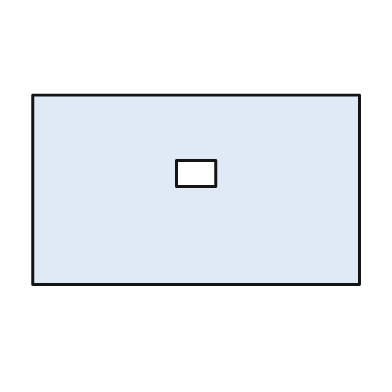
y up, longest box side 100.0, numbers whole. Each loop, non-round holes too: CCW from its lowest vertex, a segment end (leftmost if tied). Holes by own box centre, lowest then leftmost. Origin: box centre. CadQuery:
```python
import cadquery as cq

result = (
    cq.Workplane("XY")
    .moveTo(-50.0, -29.0)
    .lineTo(50.0, -29.0)
    .lineTo(50.0, 29.0)
    .lineTo(-50.0, 29.0)
    .close()
    .moveTo(-6.0, 1.0)
    .lineTo(6.0, 1.0)
    .lineTo(6.0, 9.0)
    .lineTo(-6.0, 9.0)
    .close()
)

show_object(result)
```